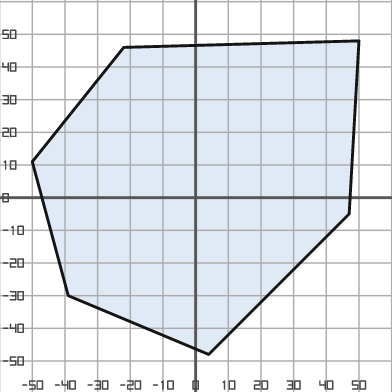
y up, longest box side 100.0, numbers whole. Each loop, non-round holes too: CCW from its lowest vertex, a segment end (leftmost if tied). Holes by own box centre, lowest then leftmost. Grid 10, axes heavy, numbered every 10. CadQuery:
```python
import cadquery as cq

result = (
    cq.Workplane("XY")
    .moveTo(4.0, -48.0)
    .lineTo(47.0, -5.0)
    .lineTo(50.0, 48.0)
    .lineTo(-22.0, 46.0)
    .lineTo(-50.0, 11.0)
    .lineTo(-39.0, -30.0)
    .close()
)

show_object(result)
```